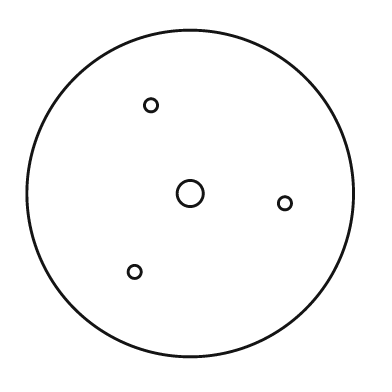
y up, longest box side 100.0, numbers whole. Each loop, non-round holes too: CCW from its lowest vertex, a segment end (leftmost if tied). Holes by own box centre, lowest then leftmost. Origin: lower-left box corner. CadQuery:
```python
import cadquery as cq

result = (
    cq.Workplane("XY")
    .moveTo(50.0, 50.0)
    .circle(50.0)
    .moveTo(33.0, 26.0)
    .circle(2.0)
    .moveTo(79.0, 47.0)
    .circle(2.0)
    .moveTo(50.0, 50.0)
    .circle(4.0)
    .moveTo(38.0, 77.0)
    .circle(2.0)
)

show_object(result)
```